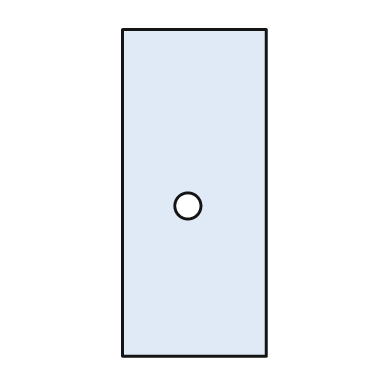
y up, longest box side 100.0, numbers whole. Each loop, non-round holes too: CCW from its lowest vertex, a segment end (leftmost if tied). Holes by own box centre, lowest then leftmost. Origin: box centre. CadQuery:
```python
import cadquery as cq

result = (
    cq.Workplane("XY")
    .moveTo(-22.0, -50.0)
    .lineTo(22.0, -50.0)
    .lineTo(22.0, 50.0)
    .lineTo(-22.0, 50.0)
    .close()
    .moveTo(-2.0, -4.0)
    .circle(4.0)
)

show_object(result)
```